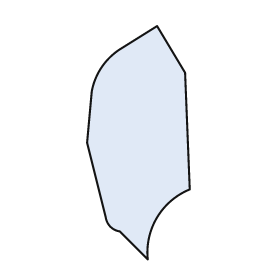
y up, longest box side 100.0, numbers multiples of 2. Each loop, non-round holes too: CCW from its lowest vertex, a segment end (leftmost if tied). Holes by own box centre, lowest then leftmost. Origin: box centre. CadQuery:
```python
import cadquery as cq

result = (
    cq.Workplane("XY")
    .moveTo(4.0, -50.0)
    .threePointArc((8.0, -32.0), (22.0, -20.0))
    .lineTo(20.0, 30.0)
    .lineTo(8.0, 50.0)
    .lineTo(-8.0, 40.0)
    .threePointArc((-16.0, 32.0), (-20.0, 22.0))
    .lineTo(-22.0, 0.0)
    .lineTo(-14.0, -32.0)
    .threePointArc((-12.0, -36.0), (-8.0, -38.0))
    .close()
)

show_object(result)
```